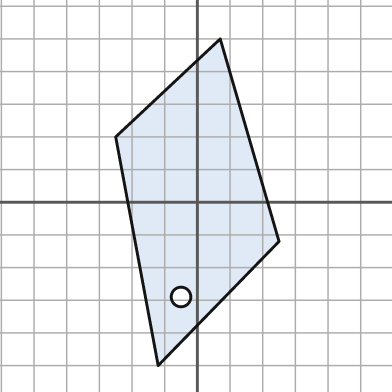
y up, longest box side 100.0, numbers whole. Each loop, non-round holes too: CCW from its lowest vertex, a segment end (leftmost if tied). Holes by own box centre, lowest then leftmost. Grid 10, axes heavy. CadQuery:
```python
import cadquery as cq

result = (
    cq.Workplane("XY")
    .moveTo(-12.0, -50.0)
    .lineTo(25.0, -12.0)
    .lineTo(7.0, 50.0)
    .lineTo(-25.0, 20.0)
    .close()
    .moveTo(-5.0, -29.0)
    .circle(3.0)
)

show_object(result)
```